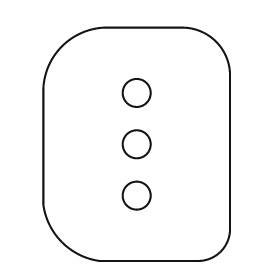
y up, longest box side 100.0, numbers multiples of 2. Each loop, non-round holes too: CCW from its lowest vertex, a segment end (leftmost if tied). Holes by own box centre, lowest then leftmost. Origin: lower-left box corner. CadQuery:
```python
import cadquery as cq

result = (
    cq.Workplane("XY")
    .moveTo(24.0, 0.0)
    .lineTo(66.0, 0.0)
    .threePointArc((76.0, 4.0), (80.0, 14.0))
    .lineTo(80.0, 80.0)
    .threePointArc((74.0, 94.0), (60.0, 100.0))
    .lineTo(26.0, 100.0)
    .threePointArc((8.0, 92.0), (0.0, 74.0))
    .lineTo(0.0, 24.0)
    .threePointArc((8.0, 8.0), (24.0, 0.0))
    .close()
    .moveTo(40.0, 28.0)
    .circle(6.0)
    .moveTo(40.0, 50.0)
    .circle(6.0)
    .moveTo(40.0, 72.0)
    .circle(6.0)
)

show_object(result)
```